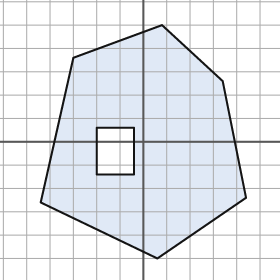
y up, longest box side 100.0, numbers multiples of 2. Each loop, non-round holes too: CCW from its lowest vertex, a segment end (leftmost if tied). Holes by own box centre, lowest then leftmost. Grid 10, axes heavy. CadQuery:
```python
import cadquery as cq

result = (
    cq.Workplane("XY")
    .moveTo(6.0, -50.0)
    .lineTo(44.0, -24.0)
    .lineTo(34.0, 26.0)
    .lineTo(8.0, 50.0)
    .lineTo(-30.0, 36.0)
    .lineTo(-44.0, -26.0)
    .close()
    .moveTo(-20.0, -14.0)
    .lineTo(-4.0, -14.0)
    .lineTo(-4.0, 6.0)
    .lineTo(-20.0, 6.0)
    .close()
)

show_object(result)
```